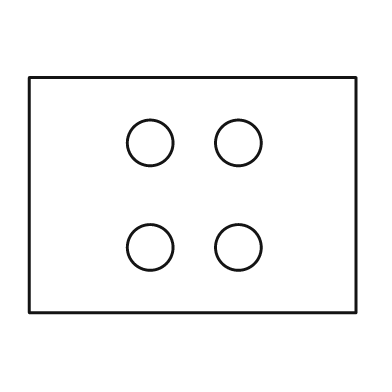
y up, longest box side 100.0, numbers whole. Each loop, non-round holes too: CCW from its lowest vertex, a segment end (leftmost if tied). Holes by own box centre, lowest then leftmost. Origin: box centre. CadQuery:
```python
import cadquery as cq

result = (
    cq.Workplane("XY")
    .moveTo(-50.0, -36.0)
    .lineTo(50.0, -36.0)
    .lineTo(50.0, 36.0)
    .lineTo(-50.0, 36.0)
    .close()
    .moveTo(-13.0, -16.0)
    .circle(7.0)
    .moveTo(14.0, -16.0)
    .circle(7.0)
    .moveTo(-13.0, 16.0)
    .circle(7.0)
    .moveTo(14.0, 16.0)
    .circle(7.0)
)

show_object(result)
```